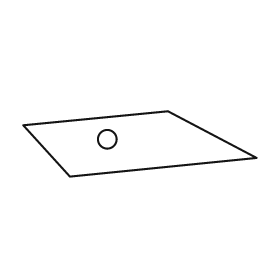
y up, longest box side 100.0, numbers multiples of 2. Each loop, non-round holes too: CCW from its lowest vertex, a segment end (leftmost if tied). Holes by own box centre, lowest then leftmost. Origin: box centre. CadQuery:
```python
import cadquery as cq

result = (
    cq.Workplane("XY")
    .moveTo(-30.0, -14.0)
    .lineTo(50.0, -6.0)
    .lineTo(12.0, 14.0)
    .lineTo(-50.0, 8.0)
    .close()
    .moveTo(-14.0, 2.0)
    .circle(4.0)
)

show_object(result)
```